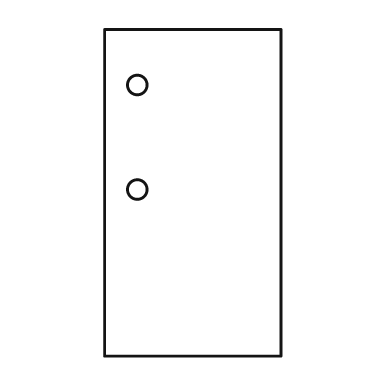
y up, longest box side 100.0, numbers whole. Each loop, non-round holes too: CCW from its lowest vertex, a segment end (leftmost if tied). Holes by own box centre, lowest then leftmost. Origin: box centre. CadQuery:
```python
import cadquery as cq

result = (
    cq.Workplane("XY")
    .moveTo(-27.0, -50.0)
    .lineTo(27.0, -50.0)
    .lineTo(27.0, 50.0)
    .lineTo(-27.0, 50.0)
    .close()
    .moveTo(-17.0, 1.0)
    .circle(3.0)
    .moveTo(-17.0, 33.0)
    .circle(3.0)
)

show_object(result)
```